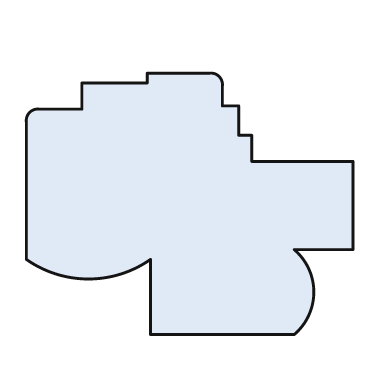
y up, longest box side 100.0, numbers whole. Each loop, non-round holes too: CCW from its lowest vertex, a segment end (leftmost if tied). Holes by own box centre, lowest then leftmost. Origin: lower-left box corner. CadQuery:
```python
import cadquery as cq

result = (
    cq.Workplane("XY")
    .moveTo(38.0, 0.0)
    .lineTo(82.0, 0.0)
    .threePointArc((88.0, 13.0), (82.0, 26.0))
    .lineTo(100.0, 26.0)
    .lineTo(100.0, 53.0)
    .lineTo(69.0, 53.0)
    .lineTo(69.0, 61.0)
    .lineTo(65.0, 61.0)
    .lineTo(65.0, 70.0)
    .lineTo(60.0, 70.0)
    .lineTo(60.0, 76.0)
    .threePointArc((59.0, 79.0), (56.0, 80.0))
    .lineTo(37.0, 80.0)
    .lineTo(37.0, 77.0)
    .lineTo(17.0, 77.0)
    .lineTo(17.0, 69.0)
    .lineTo(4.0, 69.0)
    .threePointArc((1.0, 68.0), (0.0, 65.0))
    .lineTo(0.0, 23.0)
    .threePointArc((19.0, 17.0), (38.0, 23.0))
    .close()
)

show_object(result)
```